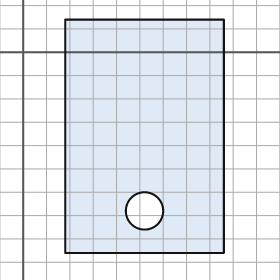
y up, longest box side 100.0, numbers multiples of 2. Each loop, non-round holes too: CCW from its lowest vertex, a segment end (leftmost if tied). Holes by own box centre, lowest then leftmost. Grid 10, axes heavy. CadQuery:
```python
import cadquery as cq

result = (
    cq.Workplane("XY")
    .moveTo(18.0, -86.0)
    .lineTo(86.0, -86.0)
    .lineTo(86.0, 14.0)
    .lineTo(18.0, 14.0)
    .close()
    .moveTo(52.0, -68.0)
    .circle(8.0)
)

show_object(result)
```